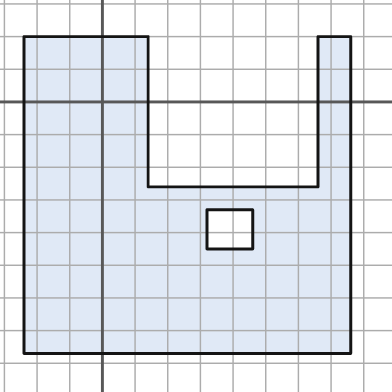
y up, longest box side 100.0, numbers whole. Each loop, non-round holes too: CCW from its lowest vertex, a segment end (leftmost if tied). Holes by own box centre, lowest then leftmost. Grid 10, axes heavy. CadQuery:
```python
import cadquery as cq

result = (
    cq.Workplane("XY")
    .moveTo(-24.0, -77.0)
    .lineTo(76.0, -77.0)
    .lineTo(76.0, 20.0)
    .lineTo(66.0, 20.0)
    .lineTo(66.0, -26.0)
    .lineTo(14.0, -26.0)
    .lineTo(14.0, 20.0)
    .lineTo(-24.0, 20.0)
    .close()
    .moveTo(32.0, -45.0)
    .lineTo(46.0, -45.0)
    .lineTo(46.0, -33.0)
    .lineTo(32.0, -33.0)
    .close()
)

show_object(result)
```